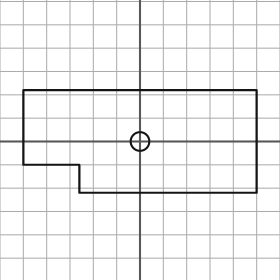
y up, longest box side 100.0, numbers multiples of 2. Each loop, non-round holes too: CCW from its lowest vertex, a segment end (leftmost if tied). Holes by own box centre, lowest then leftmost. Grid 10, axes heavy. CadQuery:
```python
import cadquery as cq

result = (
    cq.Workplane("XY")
    .moveTo(-26.0, -22.0)
    .lineTo(50.0, -22.0)
    .lineTo(50.0, 22.0)
    .lineTo(-50.0, 22.0)
    .lineTo(-50.0, -10.0)
    .lineTo(-26.0, -10.0)
    .close()
    .moveTo(0.0, 0.0)
    .circle(4.0)
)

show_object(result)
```